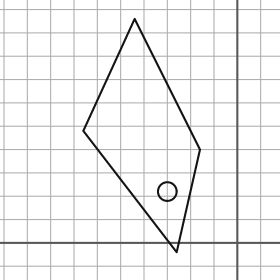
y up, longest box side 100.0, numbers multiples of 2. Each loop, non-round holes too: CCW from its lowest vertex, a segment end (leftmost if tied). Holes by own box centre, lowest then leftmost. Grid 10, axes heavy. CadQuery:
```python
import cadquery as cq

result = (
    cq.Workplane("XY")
    .moveTo(-26.0, -4.0)
    .lineTo(-16.0, 40.0)
    .lineTo(-44.0, 96.0)
    .lineTo(-66.0, 48.0)
    .close()
    .moveTo(-30.0, 22.0)
    .circle(4.0)
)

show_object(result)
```